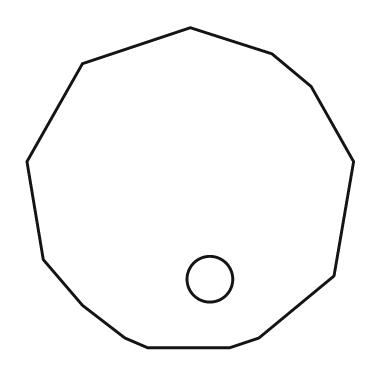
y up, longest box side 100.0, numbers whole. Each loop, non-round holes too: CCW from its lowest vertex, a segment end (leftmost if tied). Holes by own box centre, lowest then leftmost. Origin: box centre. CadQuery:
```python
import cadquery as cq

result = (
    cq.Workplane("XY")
    .moveTo(-13.0, -49.0)
    .lineTo(12.0, -49.0)
    .lineTo(21.0, -46.0)
    .lineTo(44.0, -27.0)
    .lineTo(50.0, 8.0)
    .lineTo(37.0, 31.0)
    .lineTo(25.0, 41.0)
    .lineTo(0.0, 49.0)
    .lineTo(-33.0, 38.0)
    .lineTo(-50.0, 8.0)
    .lineTo(-45.0, -22.0)
    .lineTo(-33.0, -36.0)
    .lineTo(-20.0, -46.0)
    .close()
    .moveTo(6.0, -28.0)
    .circle(7.0)
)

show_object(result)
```